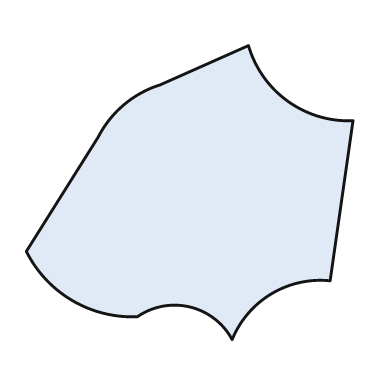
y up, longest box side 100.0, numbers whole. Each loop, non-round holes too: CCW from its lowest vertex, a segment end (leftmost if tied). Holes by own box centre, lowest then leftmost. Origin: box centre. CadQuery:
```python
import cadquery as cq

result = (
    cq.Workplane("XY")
    .moveTo(13.0, -45.0)
    .threePointArc((25.0, -31.0), (43.0, -27.0))
    .lineTo(50.0, 22.0)
    .threePointArc((30.0, 28.0), (18.0, 45.0))
    .lineTo(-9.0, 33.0)
    .threePointArc((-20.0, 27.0), (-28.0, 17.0))
    .lineTo(-50.0, -18.0)
    .threePointArc((-36.0, -33.0), (-16.0, -38.0))
    .threePointArc((0.0, -35.0), (13.0, -45.0))
    .close()
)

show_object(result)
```